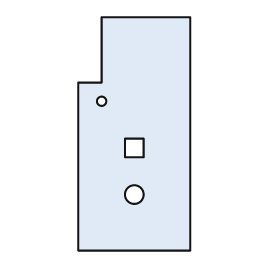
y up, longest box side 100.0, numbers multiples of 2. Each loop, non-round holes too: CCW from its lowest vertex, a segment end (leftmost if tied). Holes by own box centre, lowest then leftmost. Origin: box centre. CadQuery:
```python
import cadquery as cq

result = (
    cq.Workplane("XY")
    .moveTo(-24.0, -50.0)
    .lineTo(24.0, -50.0)
    .lineTo(24.0, 50.0)
    .lineTo(-14.0, 50.0)
    .lineTo(-14.0, 22.0)
    .lineTo(-24.0, 22.0)
    .close()
    .moveTo(0.0, -26.0)
    .circle(4.0)
    .moveTo(-4.0, -10.0)
    .lineTo(4.0, -10.0)
    .lineTo(4.0, -2.0)
    .lineTo(-4.0, -2.0)
    .close()
    .moveTo(-14.0, 14.0)
    .circle(2.0)
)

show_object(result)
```